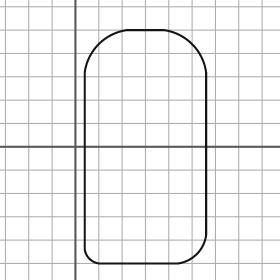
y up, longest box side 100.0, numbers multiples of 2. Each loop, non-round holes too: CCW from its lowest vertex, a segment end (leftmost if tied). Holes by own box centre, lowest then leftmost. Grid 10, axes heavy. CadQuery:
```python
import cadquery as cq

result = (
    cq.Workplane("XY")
    .moveTo(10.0, -50.0)
    .lineTo(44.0, -50.0)
    .threePointArc((52.0, -46.0), (56.0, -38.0))
    .lineTo(56.0, 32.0)
    .threePointArc((50.0, 44.0), (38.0, 50.0))
    .lineTo(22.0, 50.0)
    .threePointArc((10.0, 44.0), (4.0, 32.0))
    .lineTo(4.0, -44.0)
    .threePointArc((6.0, -48.0), (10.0, -50.0))
    .close()
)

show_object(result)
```